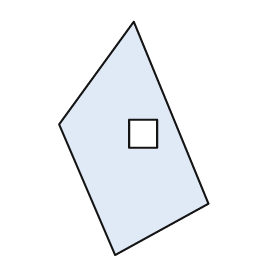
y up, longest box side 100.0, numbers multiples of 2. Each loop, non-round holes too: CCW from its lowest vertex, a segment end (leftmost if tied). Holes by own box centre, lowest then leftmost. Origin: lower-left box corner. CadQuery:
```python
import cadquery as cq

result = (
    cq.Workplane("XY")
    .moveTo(24.0, 0.0)
    .lineTo(64.0, 22.0)
    .lineTo(32.0, 100.0)
    .lineTo(0.0, 56.0)
    .close()
    .moveTo(30.0, 46.0)
    .lineTo(42.0, 46.0)
    .lineTo(42.0, 58.0)
    .lineTo(30.0, 58.0)
    .close()
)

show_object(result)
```